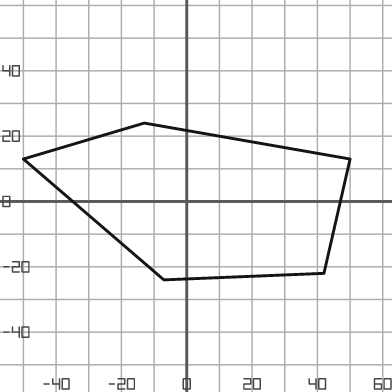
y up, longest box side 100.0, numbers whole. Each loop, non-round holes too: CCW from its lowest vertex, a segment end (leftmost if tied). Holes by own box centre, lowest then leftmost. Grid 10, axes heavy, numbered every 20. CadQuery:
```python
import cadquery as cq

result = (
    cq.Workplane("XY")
    .moveTo(-7.0, -24.0)
    .lineTo(42.0, -22.0)
    .lineTo(50.0, 13.0)
    .lineTo(-13.0, 24.0)
    .lineTo(-50.0, 13.0)
    .close()
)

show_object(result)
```